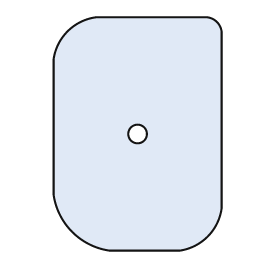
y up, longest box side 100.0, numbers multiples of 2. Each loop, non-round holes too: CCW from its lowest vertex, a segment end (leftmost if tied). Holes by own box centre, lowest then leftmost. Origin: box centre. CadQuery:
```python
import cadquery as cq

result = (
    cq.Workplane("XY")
    .moveTo(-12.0, -50.0)
    .lineTo(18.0, -50.0)
    .threePointArc((30.0, -44.0), (36.0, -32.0))
    .lineTo(36.0, 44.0)
    .threePointArc((34.0, 48.0), (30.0, 50.0))
    .lineTo(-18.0, 50.0)
    .threePointArc((-30.0, 44.0), (-36.0, 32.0))
    .lineTo(-36.0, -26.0)
    .threePointArc((-28.0, -42.0), (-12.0, -50.0))
    .close()
    .moveTo(0.0, 0.0)
    .circle(4.0)
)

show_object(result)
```